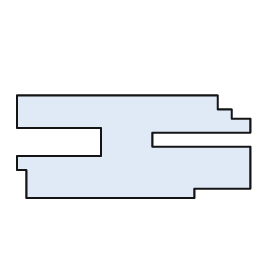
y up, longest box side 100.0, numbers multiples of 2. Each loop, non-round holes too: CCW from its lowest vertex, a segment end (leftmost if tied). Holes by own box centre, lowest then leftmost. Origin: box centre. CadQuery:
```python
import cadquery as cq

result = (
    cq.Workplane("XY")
    .moveTo(-46.0, -22.0)
    .lineTo(26.0, -22.0)
    .lineTo(26.0, -18.0)
    .lineTo(50.0, -18.0)
    .lineTo(50.0, 0.0)
    .lineTo(8.0, 0.0)
    .lineTo(8.0, 6.0)
    .lineTo(50.0, 6.0)
    .lineTo(50.0, 12.0)
    .lineTo(42.0, 12.0)
    .lineTo(42.0, 16.0)
    .lineTo(36.0, 16.0)
    .lineTo(36.0, 22.0)
    .lineTo(-50.0, 22.0)
    .lineTo(-50.0, 8.0)
    .lineTo(-14.0, 8.0)
    .lineTo(-14.0, -4.0)
    .lineTo(-50.0, -4.0)
    .lineTo(-50.0, -10.0)
    .lineTo(-46.0, -10.0)
    .close()
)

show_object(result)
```